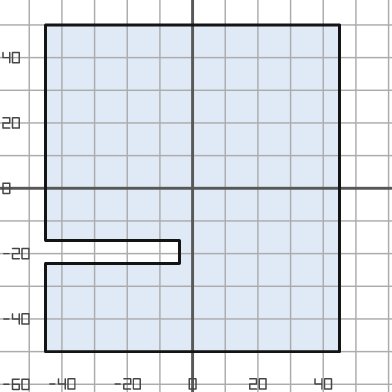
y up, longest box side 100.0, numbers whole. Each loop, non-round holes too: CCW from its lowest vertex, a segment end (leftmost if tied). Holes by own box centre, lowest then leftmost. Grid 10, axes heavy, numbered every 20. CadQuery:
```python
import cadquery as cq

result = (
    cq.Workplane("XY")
    .moveTo(-45.0, -50.0)
    .lineTo(45.0, -50.0)
    .lineTo(45.0, 50.0)
    .lineTo(-45.0, 50.0)
    .lineTo(-45.0, -16.0)
    .lineTo(-4.0, -16.0)
    .lineTo(-4.0, -23.0)
    .lineTo(-45.0, -23.0)
    .close()
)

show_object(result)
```